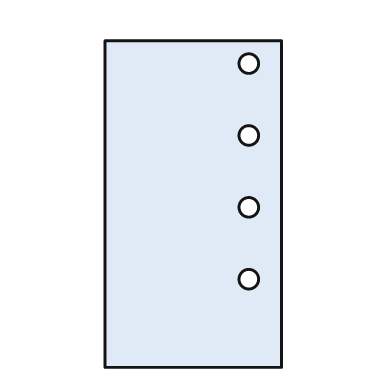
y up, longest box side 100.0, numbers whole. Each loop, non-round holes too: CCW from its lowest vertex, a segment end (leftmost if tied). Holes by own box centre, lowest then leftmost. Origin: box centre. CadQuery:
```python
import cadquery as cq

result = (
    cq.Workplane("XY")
    .moveTo(-27.0, -50.0)
    .lineTo(27.0, -50.0)
    .lineTo(27.0, 50.0)
    .lineTo(-27.0, 50.0)
    .close()
    .moveTo(17.0, -23.0)
    .circle(3.0)
    .moveTo(17.0, -1.0)
    .circle(3.0)
    .moveTo(17.0, 21.0)
    .circle(3.0)
    .moveTo(17.0, 43.0)
    .circle(3.0)
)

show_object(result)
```